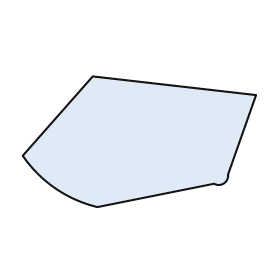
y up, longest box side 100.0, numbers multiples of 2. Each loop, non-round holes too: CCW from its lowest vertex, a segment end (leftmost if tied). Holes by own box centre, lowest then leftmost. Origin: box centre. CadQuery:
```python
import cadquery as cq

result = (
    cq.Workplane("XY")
    .moveTo(-18.0, -28.0)
    .lineTo(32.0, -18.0)
    .threePointArc((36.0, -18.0), (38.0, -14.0))
    .lineTo(50.0, 20.0)
    .lineTo(-20.0, 28.0)
    .lineTo(-50.0, -6.0)
    .threePointArc((-36.0, -20.0), (-18.0, -28.0))
    .close()
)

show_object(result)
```